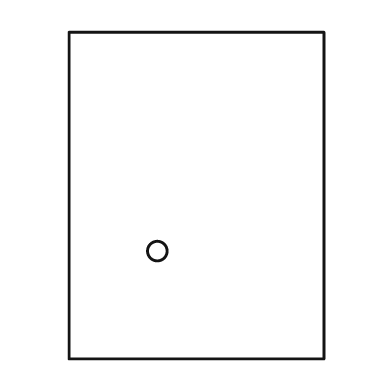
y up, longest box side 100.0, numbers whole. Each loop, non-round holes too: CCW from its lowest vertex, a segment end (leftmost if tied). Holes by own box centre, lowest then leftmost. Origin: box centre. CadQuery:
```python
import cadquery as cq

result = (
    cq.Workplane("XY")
    .moveTo(-39.0, -50.0)
    .lineTo(39.0, -50.0)
    .lineTo(39.0, 50.0)
    .lineTo(-39.0, 50.0)
    .close()
    .moveTo(-12.0, -17.0)
    .circle(3.0)
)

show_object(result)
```